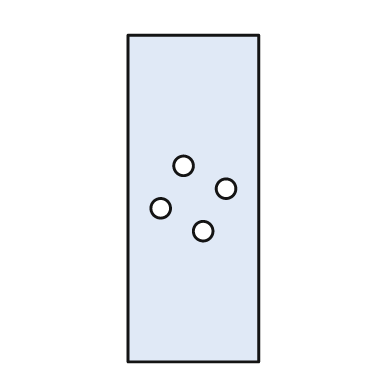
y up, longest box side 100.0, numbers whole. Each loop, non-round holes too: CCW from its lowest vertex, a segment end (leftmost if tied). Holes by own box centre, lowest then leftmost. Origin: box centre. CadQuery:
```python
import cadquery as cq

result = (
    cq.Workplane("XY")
    .moveTo(-20.0, -50.0)
    .lineTo(20.0, -50.0)
    .lineTo(20.0, 50.0)
    .lineTo(-20.0, 50.0)
    .close()
    .moveTo(3.0, -10.0)
    .circle(3.0)
    .moveTo(-10.0, -3.0)
    .circle(3.0)
    .moveTo(10.0, 3.0)
    .circle(3.0)
    .moveTo(-3.0, 10.0)
    .circle(3.0)
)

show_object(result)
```